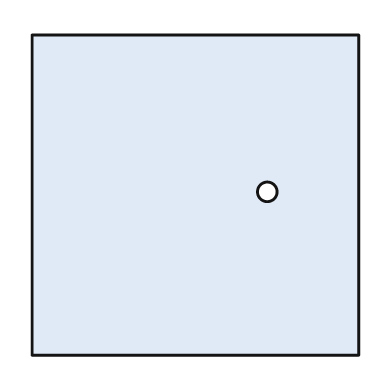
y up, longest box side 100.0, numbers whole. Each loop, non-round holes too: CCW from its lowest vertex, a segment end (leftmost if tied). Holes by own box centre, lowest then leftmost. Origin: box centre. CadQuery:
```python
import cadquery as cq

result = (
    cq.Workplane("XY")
    .moveTo(-50.0, -49.0)
    .lineTo(50.0, -49.0)
    .lineTo(50.0, 49.0)
    .lineTo(-50.0, 49.0)
    .close()
    .moveTo(22.0, 1.0)
    .circle(3.0)
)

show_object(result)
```